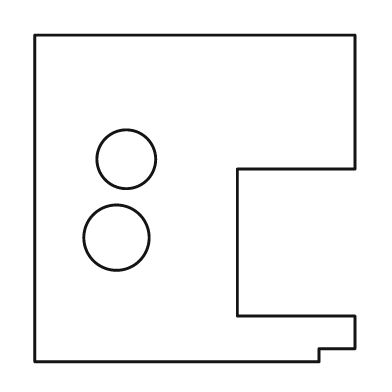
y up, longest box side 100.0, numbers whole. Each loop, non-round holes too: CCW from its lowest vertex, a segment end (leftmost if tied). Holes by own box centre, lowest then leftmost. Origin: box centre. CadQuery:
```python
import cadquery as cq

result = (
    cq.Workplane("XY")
    .moveTo(-49.0, -50.0)
    .lineTo(38.0, -50.0)
    .lineTo(38.0, -46.0)
    .lineTo(49.0, -46.0)
    .lineTo(49.0, -36.0)
    .lineTo(13.0, -36.0)
    .lineTo(13.0, 9.0)
    .lineTo(49.0, 9.0)
    .lineTo(49.0, 50.0)
    .lineTo(-49.0, 50.0)
    .close()
    .moveTo(-24.0, -12.0)
    .circle(10.0)
    .moveTo(-21.0, 12.0)
    .circle(9.0)
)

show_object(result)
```